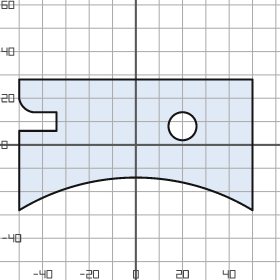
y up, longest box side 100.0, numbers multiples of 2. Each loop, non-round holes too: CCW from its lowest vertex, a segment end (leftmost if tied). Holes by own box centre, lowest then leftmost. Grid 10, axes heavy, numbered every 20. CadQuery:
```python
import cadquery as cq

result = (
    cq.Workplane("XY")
    .moveTo(-50.0, -28.0)
    .threePointArc((0.0, -14.0), (50.0, -28.0))
    .lineTo(50.0, 28.0)
    .lineTo(-50.0, 28.0)
    .lineTo(-50.0, 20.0)
    .threePointArc((-48.0, 16.0), (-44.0, 14.0))
    .lineTo(-34.0, 14.0)
    .lineTo(-34.0, 6.0)
    .lineTo(-50.0, 6.0)
    .close()
    .moveTo(20.0, 8.0)
    .circle(6.0)
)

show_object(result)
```